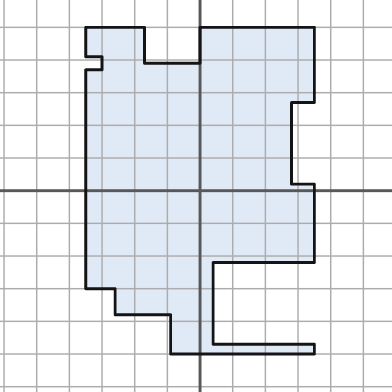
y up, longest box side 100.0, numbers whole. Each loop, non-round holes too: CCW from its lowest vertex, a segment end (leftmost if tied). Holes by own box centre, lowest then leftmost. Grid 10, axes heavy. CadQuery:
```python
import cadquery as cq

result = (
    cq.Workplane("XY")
    .moveTo(-9.0, -50.0)
    .lineTo(35.0, -50.0)
    .lineTo(35.0, -47.0)
    .lineTo(4.0, -47.0)
    .lineTo(4.0, -22.0)
    .lineTo(35.0, -22.0)
    .lineTo(35.0, 2.0)
    .lineTo(28.0, 2.0)
    .lineTo(28.0, 27.0)
    .lineTo(35.0, 27.0)
    .lineTo(35.0, 50.0)
    .lineTo(0.0, 50.0)
    .lineTo(0.0, 39.0)
    .lineTo(-17.0, 39.0)
    .lineTo(-17.0, 50.0)
    .lineTo(-35.0, 50.0)
    .lineTo(-35.0, 41.0)
    .lineTo(-30.0, 41.0)
    .lineTo(-30.0, 37.0)
    .lineTo(-35.0, 37.0)
    .lineTo(-35.0, -30.0)
    .lineTo(-26.0, -30.0)
    .lineTo(-26.0, -38.0)
    .lineTo(-9.0, -38.0)
    .close()
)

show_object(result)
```